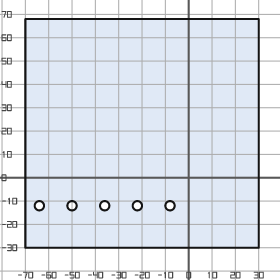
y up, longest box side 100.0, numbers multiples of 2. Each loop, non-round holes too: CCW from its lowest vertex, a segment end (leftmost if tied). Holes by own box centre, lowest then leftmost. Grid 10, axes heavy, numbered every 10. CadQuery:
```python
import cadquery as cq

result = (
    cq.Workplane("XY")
    .moveTo(-70.0, -30.0)
    .lineTo(30.0, -30.0)
    .lineTo(30.0, 68.0)
    .lineTo(-70.0, 68.0)
    .close()
    .moveTo(-64.0, -12.0)
    .circle(2.0)
    .moveTo(-50.0, -12.0)
    .circle(2.0)
    .moveTo(-36.0, -12.0)
    .circle(2.0)
    .moveTo(-22.0, -12.0)
    .circle(2.0)
    .moveTo(-8.0, -12.0)
    .circle(2.0)
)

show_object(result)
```